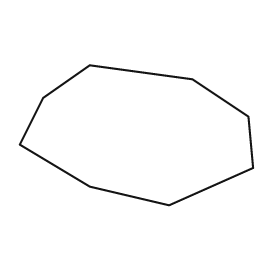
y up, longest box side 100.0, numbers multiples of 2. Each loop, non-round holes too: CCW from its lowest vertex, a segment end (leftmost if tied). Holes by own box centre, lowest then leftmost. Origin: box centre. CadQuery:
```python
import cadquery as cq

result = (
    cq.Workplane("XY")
    .moveTo(14.0, -30.0)
    .lineTo(50.0, -14.0)
    .lineTo(48.0, 8.0)
    .lineTo(24.0, 24.0)
    .lineTo(-20.0, 30.0)
    .lineTo(-40.0, 16.0)
    .lineTo(-50.0, -4.0)
    .lineTo(-20.0, -22.0)
    .close()
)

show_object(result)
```